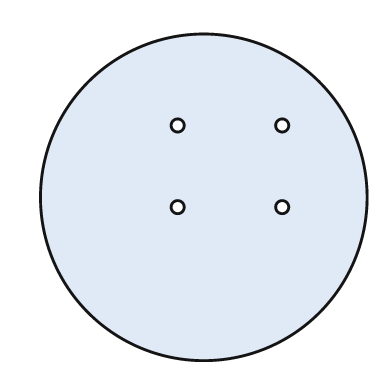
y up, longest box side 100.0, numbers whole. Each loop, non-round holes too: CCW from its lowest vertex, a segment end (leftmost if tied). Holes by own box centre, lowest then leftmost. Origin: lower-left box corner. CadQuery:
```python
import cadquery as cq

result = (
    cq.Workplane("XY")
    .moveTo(50.0, 50.0)
    .circle(50.0)
    .moveTo(42.0, 47.0)
    .circle(2.0)
    .moveTo(74.0, 47.0)
    .circle(2.0)
    .moveTo(42.0, 72.0)
    .circle(2.0)
    .moveTo(74.0, 72.0)
    .circle(2.0)
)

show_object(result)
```